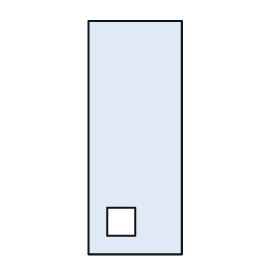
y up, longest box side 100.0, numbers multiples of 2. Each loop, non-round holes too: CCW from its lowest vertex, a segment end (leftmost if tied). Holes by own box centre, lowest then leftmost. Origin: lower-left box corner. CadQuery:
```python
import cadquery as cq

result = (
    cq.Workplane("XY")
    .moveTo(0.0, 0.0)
    .lineTo(40.0, 0.0)
    .lineTo(40.0, 100.0)
    .lineTo(0.0, 100.0)
    .close()
    .moveTo(8.0, 8.0)
    .lineTo(20.0, 8.0)
    .lineTo(20.0, 20.0)
    .lineTo(8.0, 20.0)
    .close()
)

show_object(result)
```